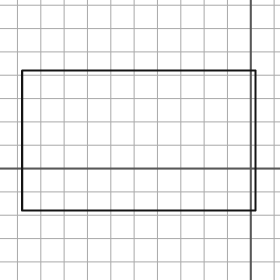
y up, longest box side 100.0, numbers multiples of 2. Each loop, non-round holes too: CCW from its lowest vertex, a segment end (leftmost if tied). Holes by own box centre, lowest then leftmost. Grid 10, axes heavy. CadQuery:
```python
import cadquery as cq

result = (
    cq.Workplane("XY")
    .moveTo(-98.0, -18.0)
    .lineTo(2.0, -18.0)
    .lineTo(2.0, 42.0)
    .lineTo(-98.0, 42.0)
    .close()
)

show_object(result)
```